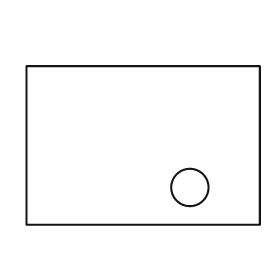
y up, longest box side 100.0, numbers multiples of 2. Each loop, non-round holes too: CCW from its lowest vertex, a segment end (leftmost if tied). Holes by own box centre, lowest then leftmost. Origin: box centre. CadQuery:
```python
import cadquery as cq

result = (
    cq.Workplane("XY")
    .moveTo(-50.0, -34.0)
    .lineTo(50.0, -34.0)
    .lineTo(50.0, 34.0)
    .lineTo(-50.0, 34.0)
    .close()
    .moveTo(20.0, -18.0)
    .circle(8.0)
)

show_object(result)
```